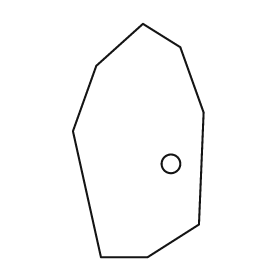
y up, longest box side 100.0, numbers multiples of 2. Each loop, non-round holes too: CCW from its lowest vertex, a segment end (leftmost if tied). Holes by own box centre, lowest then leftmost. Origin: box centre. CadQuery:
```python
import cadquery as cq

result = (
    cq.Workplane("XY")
    .moveTo(-16.0, -50.0)
    .lineTo(4.0, -50.0)
    .lineTo(26.0, -36.0)
    .lineTo(28.0, 12.0)
    .lineTo(18.0, 40.0)
    .lineTo(2.0, 50.0)
    .lineTo(-18.0, 32.0)
    .lineTo(-28.0, 4.0)
    .close()
    .moveTo(14.0, -10.0)
    .circle(4.0)
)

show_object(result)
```